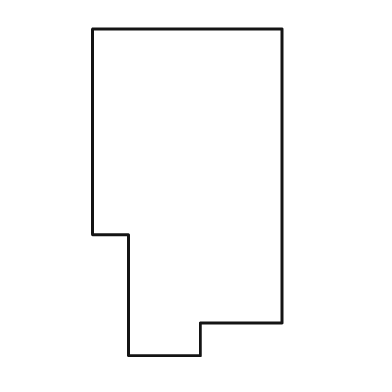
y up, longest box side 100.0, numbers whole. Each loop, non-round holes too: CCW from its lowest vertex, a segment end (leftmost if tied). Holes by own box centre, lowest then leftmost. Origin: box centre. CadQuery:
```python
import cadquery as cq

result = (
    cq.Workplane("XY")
    .moveTo(-18.0, -50.0)
    .lineTo(4.0, -50.0)
    .lineTo(4.0, -40.0)
    .lineTo(29.0, -40.0)
    .lineTo(29.0, 50.0)
    .lineTo(-29.0, 50.0)
    .lineTo(-29.0, -13.0)
    .lineTo(-18.0, -13.0)
    .close()
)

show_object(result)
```